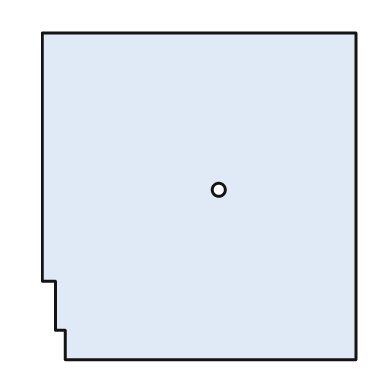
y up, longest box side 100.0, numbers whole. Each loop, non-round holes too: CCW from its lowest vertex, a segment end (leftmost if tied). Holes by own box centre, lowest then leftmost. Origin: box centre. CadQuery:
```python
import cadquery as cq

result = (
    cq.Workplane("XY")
    .moveTo(-41.0, -50.0)
    .lineTo(48.0, -50.0)
    .lineTo(48.0, 50.0)
    .lineTo(-48.0, 50.0)
    .lineTo(-48.0, -26.0)
    .lineTo(-44.0, -26.0)
    .lineTo(-44.0, -41.0)
    .lineTo(-41.0, -41.0)
    .close()
    .moveTo(6.0, 2.0)
    .circle(2.0)
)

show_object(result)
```